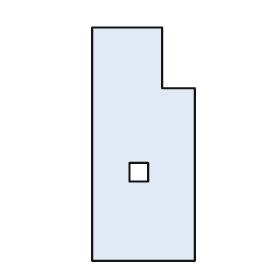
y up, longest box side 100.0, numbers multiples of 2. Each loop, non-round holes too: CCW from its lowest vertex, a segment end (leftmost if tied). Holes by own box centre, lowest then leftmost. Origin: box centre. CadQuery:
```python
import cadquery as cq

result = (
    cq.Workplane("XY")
    .moveTo(-22.0, -50.0)
    .lineTo(22.0, -50.0)
    .lineTo(22.0, 24.0)
    .lineTo(8.0, 24.0)
    .lineTo(8.0, 50.0)
    .lineTo(-22.0, 50.0)
    .close()
    .moveTo(-6.0, -16.0)
    .lineTo(2.0, -16.0)
    .lineTo(2.0, -8.0)
    .lineTo(-6.0, -8.0)
    .close()
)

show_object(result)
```